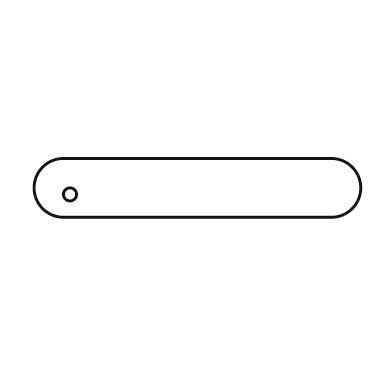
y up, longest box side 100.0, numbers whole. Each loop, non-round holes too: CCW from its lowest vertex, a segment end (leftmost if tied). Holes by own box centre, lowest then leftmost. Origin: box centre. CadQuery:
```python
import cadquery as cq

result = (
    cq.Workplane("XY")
    .moveTo(-41.0, -9.0)
    .lineTo(41.0, -9.0)
    .threePointArc((50.0, 0.0), (41.0, 9.0))
    .lineTo(-41.0, 9.0)
    .threePointArc((-50.0, 0.0), (-41.0, -9.0))
    .close()
    .moveTo(-39.0, -2.0)
    .circle(2.0)
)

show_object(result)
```